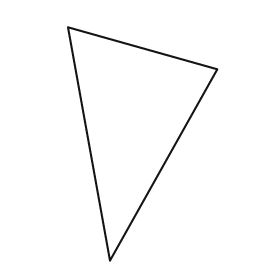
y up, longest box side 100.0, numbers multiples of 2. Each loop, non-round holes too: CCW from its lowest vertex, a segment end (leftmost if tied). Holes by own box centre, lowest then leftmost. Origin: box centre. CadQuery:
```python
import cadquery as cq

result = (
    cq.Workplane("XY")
    .moveTo(-14.0, -50.0)
    .lineTo(32.0, 32.0)
    .lineTo(-32.0, 50.0)
    .close()
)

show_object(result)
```